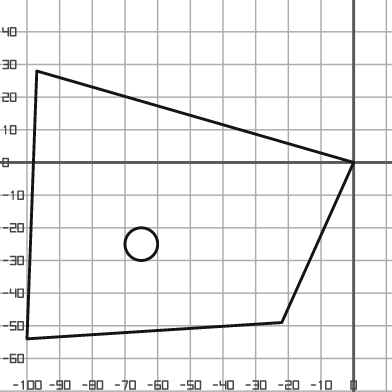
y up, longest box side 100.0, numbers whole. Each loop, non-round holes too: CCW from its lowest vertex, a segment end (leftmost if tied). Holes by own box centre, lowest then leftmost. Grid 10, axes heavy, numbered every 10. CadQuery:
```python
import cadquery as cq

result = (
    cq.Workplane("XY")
    .moveTo(-100.0, -54.0)
    .lineTo(-22.0, -49.0)
    .lineTo(0.0, 0.0)
    .lineTo(-97.0, 28.0)
    .close()
    .moveTo(-65.0, -25.0)
    .circle(5.0)
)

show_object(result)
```